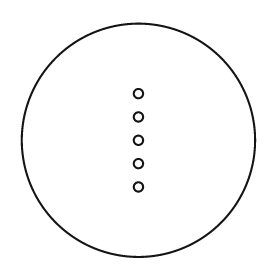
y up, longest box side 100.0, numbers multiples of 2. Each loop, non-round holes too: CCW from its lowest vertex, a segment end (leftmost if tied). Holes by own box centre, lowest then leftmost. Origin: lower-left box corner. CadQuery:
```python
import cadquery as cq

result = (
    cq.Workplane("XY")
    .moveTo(50.0, 50.0)
    .circle(50.0)
    .moveTo(50.0, 30.0)
    .circle(2.0)
    .moveTo(50.0, 40.0)
    .circle(2.0)
    .moveTo(50.0, 50.0)
    .circle(2.0)
    .moveTo(50.0, 60.0)
    .circle(2.0)
    .moveTo(50.0, 70.0)
    .circle(2.0)
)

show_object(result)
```